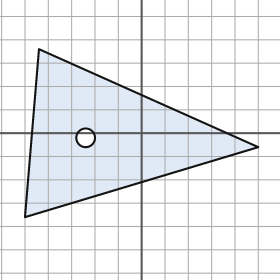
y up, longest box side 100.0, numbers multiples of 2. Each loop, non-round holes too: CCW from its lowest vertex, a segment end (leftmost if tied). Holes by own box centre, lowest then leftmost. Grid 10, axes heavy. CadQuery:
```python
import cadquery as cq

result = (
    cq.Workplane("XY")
    .moveTo(-50.0, -36.0)
    .lineTo(50.0, -6.0)
    .lineTo(-44.0, 36.0)
    .close()
    .moveTo(-24.0, -2.0)
    .circle(4.0)
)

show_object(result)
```